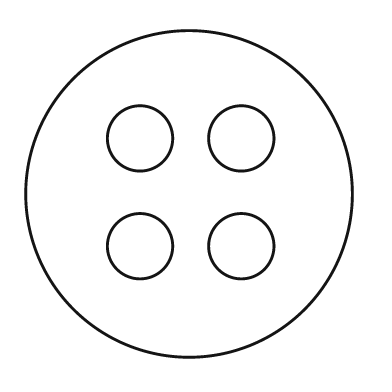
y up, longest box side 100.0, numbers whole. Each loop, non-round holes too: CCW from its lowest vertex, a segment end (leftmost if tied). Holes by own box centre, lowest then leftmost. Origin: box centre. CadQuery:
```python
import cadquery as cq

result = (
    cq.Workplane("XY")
    .moveTo(0.0, 0.0)
    .circle(50.0)
    .moveTo(-15.0, -16.0)
    .circle(10.0)
    .moveTo(16.0, -16.0)
    .circle(10.0)
    .moveTo(-15.0, 17.0)
    .circle(10.0)
    .moveTo(16.0, 17.0)
    .circle(10.0)
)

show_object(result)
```